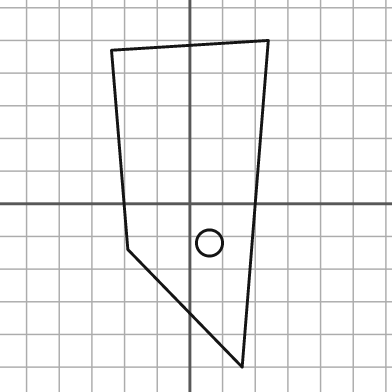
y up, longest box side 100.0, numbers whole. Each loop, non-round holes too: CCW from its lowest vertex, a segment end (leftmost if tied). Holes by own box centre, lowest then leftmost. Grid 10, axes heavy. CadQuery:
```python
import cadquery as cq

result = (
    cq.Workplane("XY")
    .moveTo(16.0, -50.0)
    .lineTo(24.0, 50.0)
    .lineTo(-24.0, 47.0)
    .lineTo(-19.0, -14.0)
    .close()
    .moveTo(6.0, -12.0)
    .circle(4.0)
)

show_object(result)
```